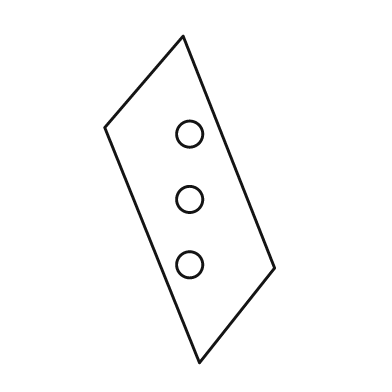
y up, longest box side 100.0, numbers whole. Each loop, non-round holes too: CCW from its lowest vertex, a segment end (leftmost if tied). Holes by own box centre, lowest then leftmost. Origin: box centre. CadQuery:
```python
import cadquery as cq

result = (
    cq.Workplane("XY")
    .moveTo(3.0, -50.0)
    .lineTo(26.0, -21.0)
    .lineTo(-2.0, 50.0)
    .lineTo(-26.0, 22.0)
    .close()
    .moveTo(0.0, -20.0)
    .circle(4.0)
    .moveTo(0.0, 0.0)
    .circle(4.0)
    .moveTo(0.0, 20.0)
    .circle(4.0)
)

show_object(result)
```